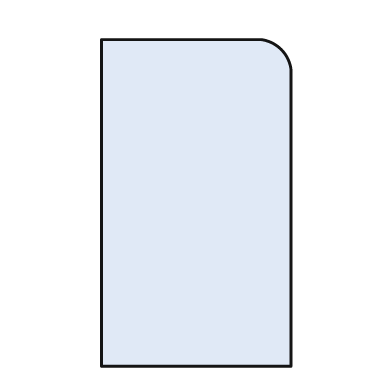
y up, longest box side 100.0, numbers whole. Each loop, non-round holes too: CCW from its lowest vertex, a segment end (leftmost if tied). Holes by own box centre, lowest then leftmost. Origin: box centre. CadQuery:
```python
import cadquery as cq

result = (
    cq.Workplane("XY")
    .moveTo(-29.0, -50.0)
    .lineTo(29.0, -50.0)
    .lineTo(29.0, 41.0)
    .threePointArc((26.0, 47.0), (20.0, 50.0))
    .lineTo(-29.0, 50.0)
    .close()
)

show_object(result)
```